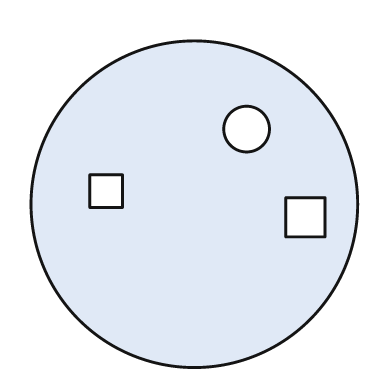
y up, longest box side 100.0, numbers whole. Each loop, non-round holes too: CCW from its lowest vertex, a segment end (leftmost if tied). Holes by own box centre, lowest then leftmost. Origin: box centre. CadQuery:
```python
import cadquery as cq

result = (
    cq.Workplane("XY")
    .moveTo(0.0, 0.0)
    .circle(50.0)
    .moveTo(28.0, -10.0)
    .lineTo(40.0, -10.0)
    .lineTo(40.0, 2.0)
    .lineTo(28.0, 2.0)
    .close()
    .moveTo(-32.0, -1.0)
    .lineTo(-22.0, -1.0)
    .lineTo(-22.0, 9.0)
    .lineTo(-32.0, 9.0)
    .close()
    .moveTo(16.0, 23.0)
    .circle(7.0)
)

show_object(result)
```